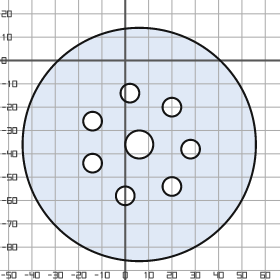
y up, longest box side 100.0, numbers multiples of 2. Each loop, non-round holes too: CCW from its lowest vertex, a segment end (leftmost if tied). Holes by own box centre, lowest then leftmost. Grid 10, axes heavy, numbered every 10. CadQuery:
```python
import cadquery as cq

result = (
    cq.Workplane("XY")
    .moveTo(6.0, -36.0)
    .circle(50.0)
    .moveTo(0.0, -58.0)
    .circle(4.0)
    .moveTo(20.0, -54.0)
    .circle(4.0)
    .moveTo(-14.0, -44.0)
    .circle(4.0)
    .moveTo(28.0, -38.0)
    .circle(4.0)
    .moveTo(6.0, -36.0)
    .circle(6.0)
    .moveTo(-14.0, -26.0)
    .circle(4.0)
    .moveTo(20.0, -20.0)
    .circle(4.0)
    .moveTo(2.0, -14.0)
    .circle(4.0)
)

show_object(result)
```